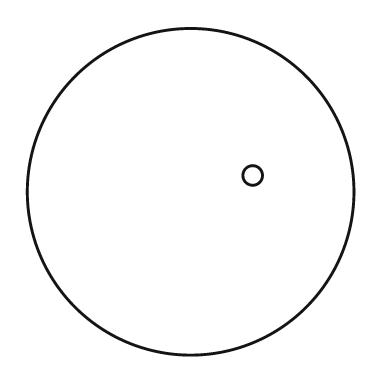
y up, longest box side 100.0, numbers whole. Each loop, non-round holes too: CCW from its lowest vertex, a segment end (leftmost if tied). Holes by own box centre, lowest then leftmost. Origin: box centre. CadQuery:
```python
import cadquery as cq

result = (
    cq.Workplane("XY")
    .moveTo(0.0, 0.0)
    .circle(50.0)
    .moveTo(19.0, 5.0)
    .circle(3.0)
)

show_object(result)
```